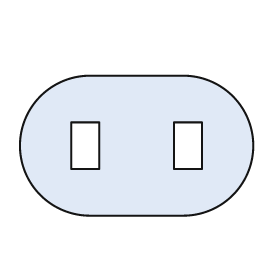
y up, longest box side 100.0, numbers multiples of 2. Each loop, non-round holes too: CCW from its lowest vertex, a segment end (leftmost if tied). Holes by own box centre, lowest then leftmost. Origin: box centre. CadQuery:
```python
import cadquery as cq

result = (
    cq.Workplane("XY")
    .moveTo(-20.0, -30.0)
    .lineTo(20.0, -30.0)
    .threePointArc((50.0, 0.0), (20.0, 30.0))
    .lineTo(-20.0, 30.0)
    .threePointArc((-50.0, 0.0), (-20.0, -30.0))
    .close()
    .moveTo(-28.0, -10.0)
    .lineTo(-16.0, -10.0)
    .lineTo(-16.0, 10.0)
    .lineTo(-28.0, 10.0)
    .close()
    .moveTo(16.0, -10.0)
    .lineTo(28.0, -10.0)
    .lineTo(28.0, 10.0)
    .lineTo(16.0, 10.0)
    .close()
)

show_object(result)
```